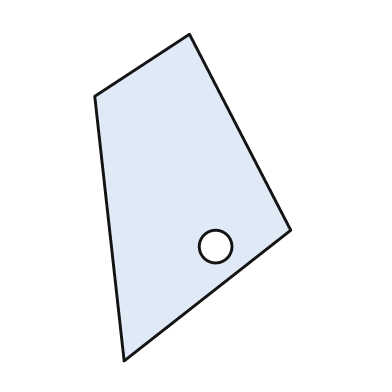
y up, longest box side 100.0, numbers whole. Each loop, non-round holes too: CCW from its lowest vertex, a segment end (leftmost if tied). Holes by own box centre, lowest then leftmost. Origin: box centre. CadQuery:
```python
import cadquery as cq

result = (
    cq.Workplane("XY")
    .moveTo(-21.0, -50.0)
    .lineTo(30.0, -10.0)
    .lineTo(-1.0, 50.0)
    .lineTo(-30.0, 31.0)
    .close()
    .moveTo(7.0, -15.0)
    .circle(5.0)
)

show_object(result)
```